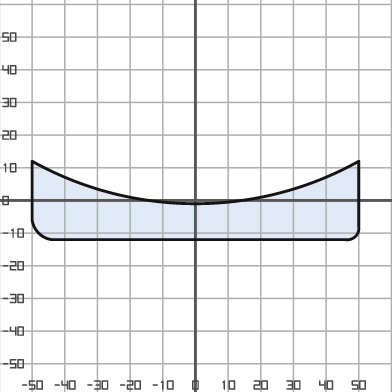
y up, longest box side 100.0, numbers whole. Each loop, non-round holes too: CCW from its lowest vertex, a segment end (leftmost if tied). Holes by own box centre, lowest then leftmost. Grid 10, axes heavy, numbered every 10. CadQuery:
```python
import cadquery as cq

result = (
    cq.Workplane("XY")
    .moveTo(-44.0, -12.0)
    .lineTo(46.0, -12.0)
    .threePointArc((49.0, -11.0), (50.0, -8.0))
    .lineTo(50.0, 12.0)
    .threePointArc((0.0, -1.0), (-50.0, 12.0))
    .lineTo(-50.0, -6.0)
    .threePointArc((-48.0, -10.0), (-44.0, -12.0))
    .close()
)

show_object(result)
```